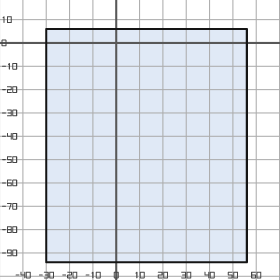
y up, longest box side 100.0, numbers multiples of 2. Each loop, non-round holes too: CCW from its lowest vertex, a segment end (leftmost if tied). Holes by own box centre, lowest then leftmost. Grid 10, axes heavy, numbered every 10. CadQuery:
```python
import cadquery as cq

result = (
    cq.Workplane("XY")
    .moveTo(-30.0, -94.0)
    .lineTo(56.0, -94.0)
    .lineTo(56.0, 6.0)
    .lineTo(-30.0, 6.0)
    .close()
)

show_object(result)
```